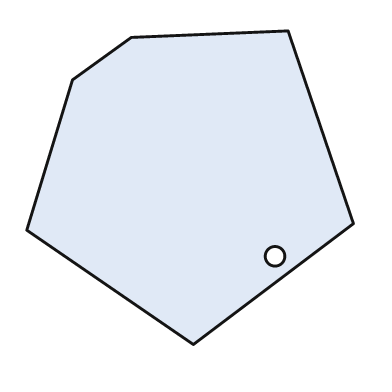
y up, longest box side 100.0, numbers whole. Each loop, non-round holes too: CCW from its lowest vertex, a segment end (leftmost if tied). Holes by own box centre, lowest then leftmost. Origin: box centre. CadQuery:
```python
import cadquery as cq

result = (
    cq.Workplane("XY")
    .moveTo(1.0, -48.0)
    .lineTo(50.0, -11.0)
    .lineTo(30.0, 48.0)
    .lineTo(-18.0, 46.0)
    .lineTo(-36.0, 33.0)
    .lineTo(-50.0, -13.0)
    .close()
    .moveTo(26.0, -21.0)
    .circle(3.0)
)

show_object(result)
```